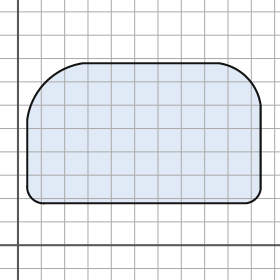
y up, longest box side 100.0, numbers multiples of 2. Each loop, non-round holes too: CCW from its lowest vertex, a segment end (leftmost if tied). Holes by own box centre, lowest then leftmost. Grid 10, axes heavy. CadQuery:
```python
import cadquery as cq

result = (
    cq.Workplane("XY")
    .moveTo(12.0, 18.0)
    .lineTo(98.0, 18.0)
    .threePointArc((102.0, 20.0), (104.0, 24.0))
    .lineTo(104.0, 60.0)
    .threePointArc((98.0, 72.0), (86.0, 78.0))
    .lineTo(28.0, 78.0)
    .threePointArc((12.0, 70.0), (4.0, 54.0))
    .lineTo(4.0, 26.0)
    .threePointArc((6.0, 20.0), (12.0, 18.0))
    .close()
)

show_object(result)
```